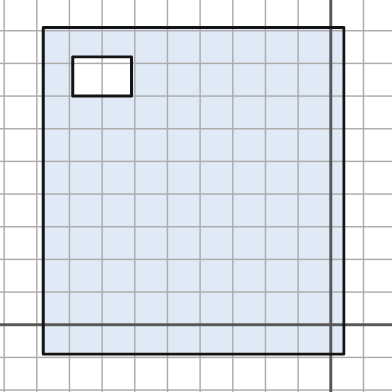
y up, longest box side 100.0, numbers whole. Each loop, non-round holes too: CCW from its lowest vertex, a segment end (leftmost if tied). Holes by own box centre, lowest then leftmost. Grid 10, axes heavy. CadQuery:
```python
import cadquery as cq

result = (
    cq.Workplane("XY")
    .moveTo(-88.0, -9.0)
    .lineTo(4.0, -9.0)
    .lineTo(4.0, 91.0)
    .lineTo(-88.0, 91.0)
    .close()
    .moveTo(-79.0, 70.0)
    .lineTo(-61.0, 70.0)
    .lineTo(-61.0, 82.0)
    .lineTo(-79.0, 82.0)
    .close()
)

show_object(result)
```